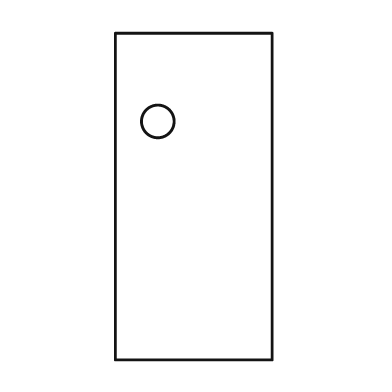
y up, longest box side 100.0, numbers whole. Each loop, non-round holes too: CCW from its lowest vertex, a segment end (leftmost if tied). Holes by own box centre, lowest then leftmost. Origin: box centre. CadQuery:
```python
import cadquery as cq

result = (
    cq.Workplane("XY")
    .moveTo(-24.0, -50.0)
    .lineTo(24.0, -50.0)
    .lineTo(24.0, 50.0)
    .lineTo(-24.0, 50.0)
    .close()
    .moveTo(-11.0, 23.0)
    .circle(5.0)
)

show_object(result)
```